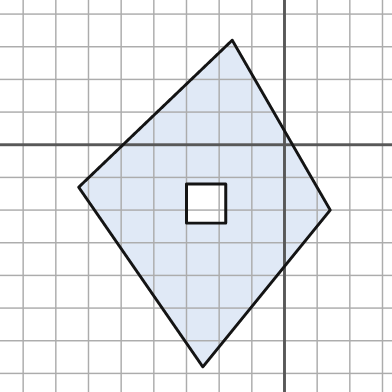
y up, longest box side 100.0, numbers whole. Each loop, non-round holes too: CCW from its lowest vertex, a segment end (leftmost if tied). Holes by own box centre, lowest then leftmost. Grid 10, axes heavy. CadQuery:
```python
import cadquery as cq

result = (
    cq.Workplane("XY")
    .moveTo(-25.0, -68.0)
    .lineTo(14.0, -20.0)
    .lineTo(-16.0, 32.0)
    .lineTo(-63.0, -13.0)
    .close()
    .moveTo(-30.0, -24.0)
    .lineTo(-18.0, -24.0)
    .lineTo(-18.0, -12.0)
    .lineTo(-30.0, -12.0)
    .close()
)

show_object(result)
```